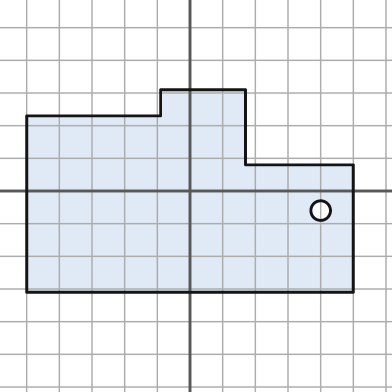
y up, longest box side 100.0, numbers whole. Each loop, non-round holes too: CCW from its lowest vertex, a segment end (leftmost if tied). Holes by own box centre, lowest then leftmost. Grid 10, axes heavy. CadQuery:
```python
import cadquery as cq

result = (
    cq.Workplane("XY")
    .moveTo(-50.0, -31.0)
    .lineTo(50.0, -31.0)
    .lineTo(50.0, 8.0)
    .lineTo(17.0, 8.0)
    .lineTo(17.0, 31.0)
    .lineTo(-9.0, 31.0)
    .lineTo(-9.0, 23.0)
    .lineTo(-50.0, 23.0)
    .close()
    .moveTo(40.0, -6.0)
    .circle(3.0)
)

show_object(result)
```